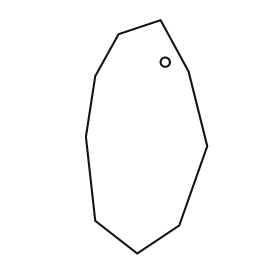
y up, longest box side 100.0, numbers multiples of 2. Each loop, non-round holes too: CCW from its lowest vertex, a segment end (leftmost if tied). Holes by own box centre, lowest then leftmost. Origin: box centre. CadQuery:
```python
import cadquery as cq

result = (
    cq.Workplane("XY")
    .moveTo(-4.0, -50.0)
    .lineTo(14.0, -38.0)
    .lineTo(26.0, -4.0)
    .lineTo(18.0, 28.0)
    .lineTo(6.0, 50.0)
    .lineTo(-12.0, 44.0)
    .lineTo(-22.0, 26.0)
    .lineTo(-26.0, 0.0)
    .lineTo(-22.0, -36.0)
    .close()
    .moveTo(8.0, 32.0)
    .circle(2.0)
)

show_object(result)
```